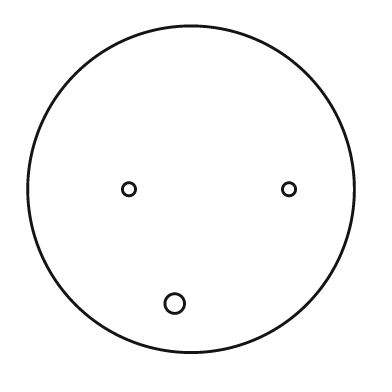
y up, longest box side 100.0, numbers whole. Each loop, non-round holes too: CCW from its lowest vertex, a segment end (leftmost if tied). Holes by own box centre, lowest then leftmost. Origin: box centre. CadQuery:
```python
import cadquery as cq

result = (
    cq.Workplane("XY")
    .moveTo(0.0, 0.0)
    .circle(50.0)
    .moveTo(-5.0, -35.0)
    .circle(3.0)
    .moveTo(-19.0, 0.0)
    .circle(2.0)
    .moveTo(30.0, 0.0)
    .circle(2.0)
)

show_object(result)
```